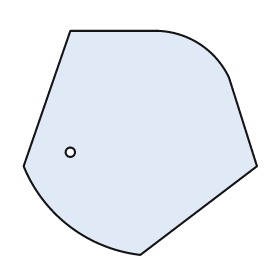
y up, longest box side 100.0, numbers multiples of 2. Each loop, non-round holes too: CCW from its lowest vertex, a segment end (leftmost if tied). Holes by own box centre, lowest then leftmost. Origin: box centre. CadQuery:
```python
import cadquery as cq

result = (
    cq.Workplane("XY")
    .moveTo(0.0, -48.0)
    .lineTo(50.0, -10.0)
    .lineTo(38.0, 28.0)
    .threePointArc((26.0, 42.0), (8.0, 48.0))
    .lineTo(-30.0, 48.0)
    .lineTo(-50.0, -10.0)
    .threePointArc((-30.0, -36.0), (0.0, -48.0))
    .close()
    .moveTo(-30.0, -4.0)
    .circle(2.0)
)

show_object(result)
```